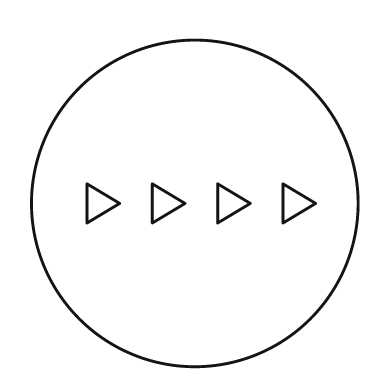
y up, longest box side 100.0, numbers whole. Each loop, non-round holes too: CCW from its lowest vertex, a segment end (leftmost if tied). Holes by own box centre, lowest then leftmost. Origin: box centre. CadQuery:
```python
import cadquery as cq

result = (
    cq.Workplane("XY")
    .moveTo(0.0, 0.0)
    .circle(50.0)
    .moveTo(-33.0, -6.0)
    .lineTo(-23.0, 0.0)
    .lineTo(-33.0, 6.0)
    .close()
    .moveTo(-13.0, -6.0)
    .lineTo(-3.0, 0.0)
    .lineTo(-13.0, 6.0)
    .close()
    .moveTo(7.0, -6.0)
    .lineTo(17.0, 0.0)
    .lineTo(7.0, 6.0)
    .close()
    .moveTo(27.0, -6.0)
    .lineTo(37.0, 0.0)
    .lineTo(27.0, 6.0)
    .close()
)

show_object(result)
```